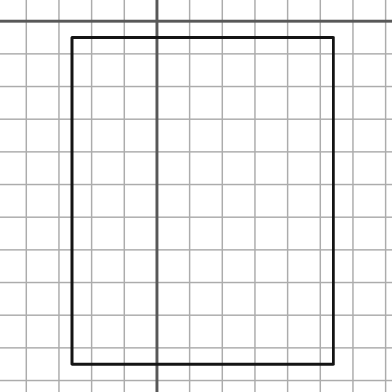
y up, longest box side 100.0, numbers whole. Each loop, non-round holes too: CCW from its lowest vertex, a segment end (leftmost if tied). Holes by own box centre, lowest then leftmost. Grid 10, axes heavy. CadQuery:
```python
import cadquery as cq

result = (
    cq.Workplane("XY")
    .moveTo(-26.0, -105.0)
    .lineTo(54.0, -105.0)
    .lineTo(54.0, -5.0)
    .lineTo(-26.0, -5.0)
    .close()
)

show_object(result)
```